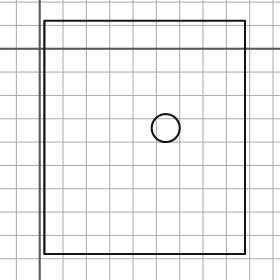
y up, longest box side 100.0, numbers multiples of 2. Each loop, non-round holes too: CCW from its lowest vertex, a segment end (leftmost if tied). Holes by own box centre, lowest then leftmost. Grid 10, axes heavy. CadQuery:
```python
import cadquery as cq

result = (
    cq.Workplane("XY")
    .moveTo(2.0, -88.0)
    .lineTo(88.0, -88.0)
    .lineTo(88.0, 12.0)
    .lineTo(2.0, 12.0)
    .close()
    .moveTo(54.0, -34.0)
    .circle(6.0)
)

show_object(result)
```